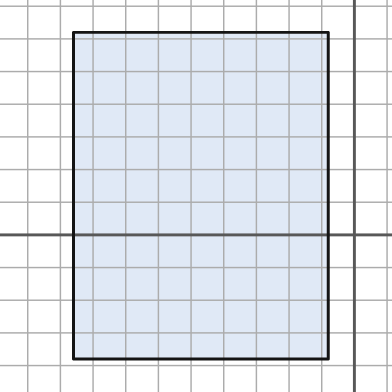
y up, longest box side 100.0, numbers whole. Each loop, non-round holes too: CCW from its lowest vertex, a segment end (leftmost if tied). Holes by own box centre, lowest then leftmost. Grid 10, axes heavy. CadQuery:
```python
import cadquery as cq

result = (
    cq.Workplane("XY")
    .moveTo(-86.0, -38.0)
    .lineTo(-8.0, -38.0)
    .lineTo(-8.0, 62.0)
    .lineTo(-86.0, 62.0)
    .close()
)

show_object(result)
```